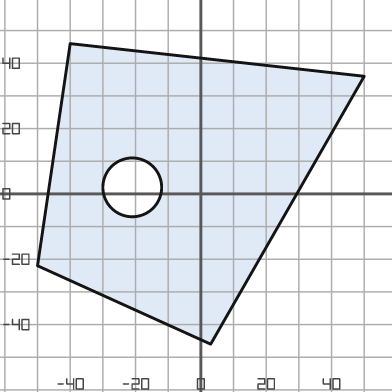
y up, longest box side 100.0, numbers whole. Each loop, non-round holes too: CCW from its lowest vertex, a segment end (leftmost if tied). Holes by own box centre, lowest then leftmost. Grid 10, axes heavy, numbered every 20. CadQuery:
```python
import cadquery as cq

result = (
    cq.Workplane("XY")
    .moveTo(3.0, -46.0)
    .lineTo(50.0, 36.0)
    .lineTo(-40.0, 46.0)
    .lineTo(-50.0, -22.0)
    .close()
    .moveTo(-21.0, 2.0)
    .circle(9.0)
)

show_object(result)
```